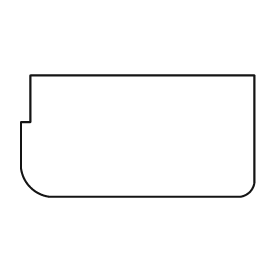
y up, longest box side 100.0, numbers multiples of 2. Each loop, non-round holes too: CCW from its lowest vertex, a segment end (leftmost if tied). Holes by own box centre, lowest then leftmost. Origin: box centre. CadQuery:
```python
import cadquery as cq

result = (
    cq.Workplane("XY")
    .moveTo(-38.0, -26.0)
    .lineTo(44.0, -26.0)
    .threePointArc((48.0, -24.0), (50.0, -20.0))
    .lineTo(50.0, 26.0)
    .lineTo(-46.0, 26.0)
    .lineTo(-46.0, 6.0)
    .lineTo(-50.0, 6.0)
    .lineTo(-50.0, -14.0)
    .threePointArc((-46.0, -22.0), (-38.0, -26.0))
    .close()
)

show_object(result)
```